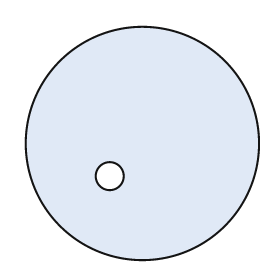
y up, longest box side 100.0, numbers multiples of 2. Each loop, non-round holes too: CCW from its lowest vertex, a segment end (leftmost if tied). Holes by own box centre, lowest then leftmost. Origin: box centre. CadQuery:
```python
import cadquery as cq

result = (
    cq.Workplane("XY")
    .moveTo(0.0, 0.0)
    .circle(50.0)
    .moveTo(-14.0, -14.0)
    .circle(6.0)
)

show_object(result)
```